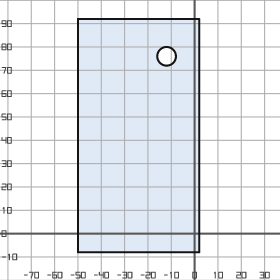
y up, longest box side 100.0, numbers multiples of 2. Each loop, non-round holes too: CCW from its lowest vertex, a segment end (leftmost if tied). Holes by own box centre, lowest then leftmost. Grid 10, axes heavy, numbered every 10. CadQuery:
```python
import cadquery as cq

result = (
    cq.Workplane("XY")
    .moveTo(-50.0, -8.0)
    .lineTo(2.0, -8.0)
    .lineTo(2.0, 92.0)
    .lineTo(-50.0, 92.0)
    .close()
    .moveTo(-12.0, 76.0)
    .circle(4.0)
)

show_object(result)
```